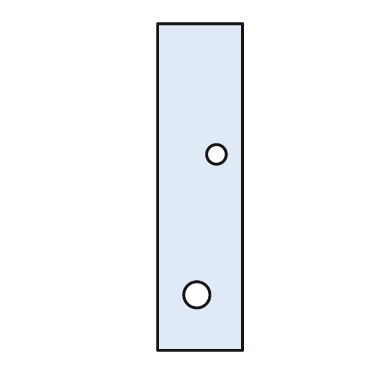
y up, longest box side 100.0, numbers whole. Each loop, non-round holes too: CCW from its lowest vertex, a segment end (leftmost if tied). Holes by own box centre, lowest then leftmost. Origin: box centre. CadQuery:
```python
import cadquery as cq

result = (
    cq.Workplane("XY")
    .moveTo(-13.0, -50.0)
    .lineTo(13.0, -50.0)
    .lineTo(13.0, 50.0)
    .lineTo(-13.0, 50.0)
    .close()
    .moveTo(-1.0, -33.0)
    .circle(4.0)
    .moveTo(5.0, 10.0)
    .circle(3.0)
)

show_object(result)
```